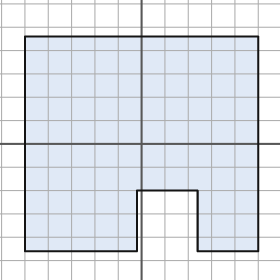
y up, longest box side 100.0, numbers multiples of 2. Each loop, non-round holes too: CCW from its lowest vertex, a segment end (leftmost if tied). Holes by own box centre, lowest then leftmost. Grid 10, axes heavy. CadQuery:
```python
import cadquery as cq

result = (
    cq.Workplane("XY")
    .moveTo(-50.0, -46.0)
    .lineTo(-2.0, -46.0)
    .lineTo(-2.0, -20.0)
    .lineTo(24.0, -20.0)
    .lineTo(24.0, -46.0)
    .lineTo(50.0, -46.0)
    .lineTo(50.0, 46.0)
    .lineTo(-50.0, 46.0)
    .close()
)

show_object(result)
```